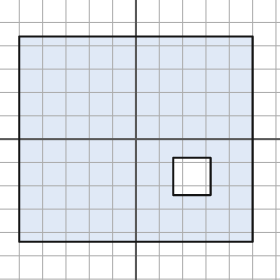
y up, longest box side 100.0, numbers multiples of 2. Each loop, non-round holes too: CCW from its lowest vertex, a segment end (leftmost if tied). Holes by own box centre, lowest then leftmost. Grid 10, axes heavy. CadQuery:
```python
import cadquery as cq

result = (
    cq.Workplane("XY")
    .moveTo(-50.0, -44.0)
    .lineTo(50.0, -44.0)
    .lineTo(50.0, 44.0)
    .lineTo(-50.0, 44.0)
    .close()
    .moveTo(16.0, -24.0)
    .lineTo(32.0, -24.0)
    .lineTo(32.0, -8.0)
    .lineTo(16.0, -8.0)
    .close()
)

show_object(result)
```